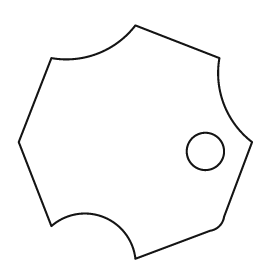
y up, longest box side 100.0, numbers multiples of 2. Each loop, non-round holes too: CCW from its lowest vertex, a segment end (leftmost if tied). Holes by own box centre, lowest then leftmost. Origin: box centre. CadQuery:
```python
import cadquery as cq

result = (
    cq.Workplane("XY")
    .moveTo(0.0, -50.0)
    .lineTo(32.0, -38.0)
    .threePointArc((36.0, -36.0), (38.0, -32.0))
    .lineTo(50.0, 0.0)
    .threePointArc((38.0, 16.0), (36.0, 36.0))
    .lineTo(0.0, 50.0)
    .threePointArc((-16.0, 38.0), (-36.0, 36.0))
    .lineTo(-50.0, 0.0)
    .lineTo(-36.0, -36.0)
    .threePointArc((-14.0, -32.0), (0.0, -50.0))
    .close()
    .moveTo(30.0, -4.0)
    .circle(8.0)
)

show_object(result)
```